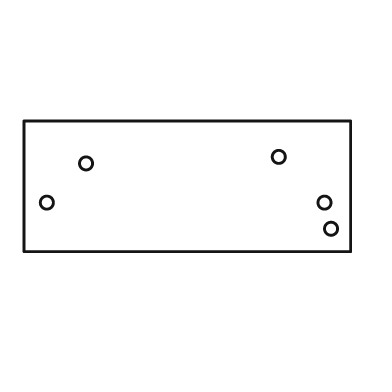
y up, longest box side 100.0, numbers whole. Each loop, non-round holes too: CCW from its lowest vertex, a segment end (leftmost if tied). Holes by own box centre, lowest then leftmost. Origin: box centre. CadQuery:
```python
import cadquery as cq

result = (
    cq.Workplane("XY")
    .moveTo(-50.0, -20.0)
    .lineTo(50.0, -20.0)
    .lineTo(50.0, 20.0)
    .lineTo(-50.0, 20.0)
    .close()
    .moveTo(44.0, -13.0)
    .circle(2.0)
    .moveTo(-43.0, -5.0)
    .circle(2.0)
    .moveTo(42.0, -5.0)
    .circle(2.0)
    .moveTo(-31.0, 7.0)
    .circle(2.0)
    .moveTo(28.0, 9.0)
    .circle(2.0)
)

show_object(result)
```